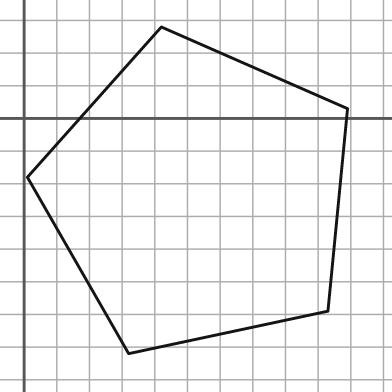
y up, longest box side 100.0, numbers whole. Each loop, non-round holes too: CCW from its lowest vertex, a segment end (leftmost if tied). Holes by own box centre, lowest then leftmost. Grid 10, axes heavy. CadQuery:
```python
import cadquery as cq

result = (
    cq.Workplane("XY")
    .moveTo(32.0, -72.0)
    .lineTo(93.0, -59.0)
    .lineTo(99.0, 3.0)
    .lineTo(42.0, 28.0)
    .lineTo(1.0, -18.0)
    .close()
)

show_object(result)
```